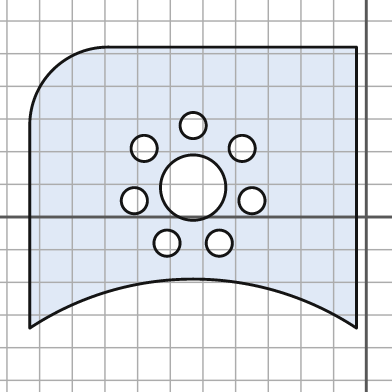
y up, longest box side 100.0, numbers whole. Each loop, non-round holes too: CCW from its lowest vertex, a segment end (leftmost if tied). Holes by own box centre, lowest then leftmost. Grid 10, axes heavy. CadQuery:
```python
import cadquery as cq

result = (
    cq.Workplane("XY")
    .moveTo(-103.0, -34.0)
    .threePointArc((-53.0, -19.0), (-3.0, -34.0))
    .lineTo(-3.0, 52.0)
    .lineTo(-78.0, 52.0)
    .threePointArc((-96.0, 45.0), (-103.0, 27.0))
    .close()
    .moveTo(-61.0, -8.0)
    .circle(4.0)
    .moveTo(-45.0, -8.0)
    .circle(4.0)
    .moveTo(-71.0, 5.0)
    .circle(4.0)
    .moveTo(-35.0, 5.0)
    .circle(4.0)
    .moveTo(-53.0, 9.0)
    .circle(10.0)
    .moveTo(-68.0, 21.0)
    .circle(4.0)
    .moveTo(-38.0, 21.0)
    .circle(4.0)
    .moveTo(-53.0, 28.0)
    .circle(4.0)
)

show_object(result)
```